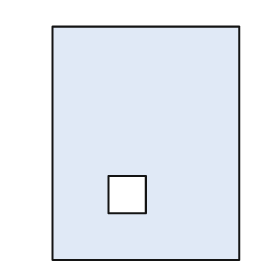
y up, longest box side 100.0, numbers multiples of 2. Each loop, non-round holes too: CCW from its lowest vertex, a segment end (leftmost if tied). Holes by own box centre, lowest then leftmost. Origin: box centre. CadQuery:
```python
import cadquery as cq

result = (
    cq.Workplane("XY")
    .moveTo(-40.0, -50.0)
    .lineTo(40.0, -50.0)
    .lineTo(40.0, 50.0)
    .lineTo(-40.0, 50.0)
    .close()
    .moveTo(-16.0, -30.0)
    .lineTo(0.0, -30.0)
    .lineTo(0.0, -14.0)
    .lineTo(-16.0, -14.0)
    .close()
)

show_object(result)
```